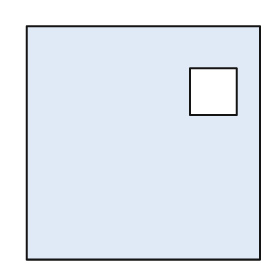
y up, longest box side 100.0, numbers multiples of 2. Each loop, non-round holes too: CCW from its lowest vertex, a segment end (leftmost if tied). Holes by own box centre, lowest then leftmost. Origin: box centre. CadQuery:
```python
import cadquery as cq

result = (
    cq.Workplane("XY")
    .moveTo(-50.0, -50.0)
    .lineTo(50.0, -50.0)
    .lineTo(50.0, 50.0)
    .lineTo(-50.0, 50.0)
    .close()
    .moveTo(20.0, 12.0)
    .lineTo(40.0, 12.0)
    .lineTo(40.0, 32.0)
    .lineTo(20.0, 32.0)
    .close()
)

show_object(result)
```